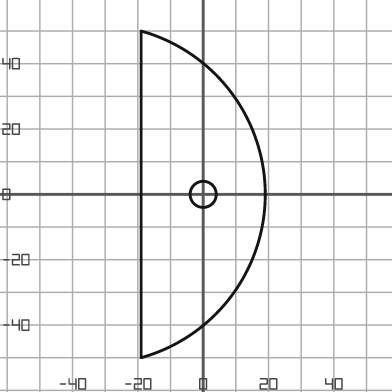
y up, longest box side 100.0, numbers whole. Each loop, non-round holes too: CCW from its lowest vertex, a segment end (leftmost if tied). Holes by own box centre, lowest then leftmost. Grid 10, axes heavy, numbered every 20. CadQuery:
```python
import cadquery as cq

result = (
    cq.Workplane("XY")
    .moveTo(-19.0, -50.0)
    .threePointArc((19.0, 0.0), (-19.0, 50.0))
    .close()
    .moveTo(0.0, 0.0)
    .circle(4.0)
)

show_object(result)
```